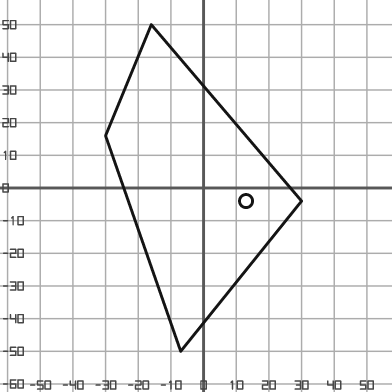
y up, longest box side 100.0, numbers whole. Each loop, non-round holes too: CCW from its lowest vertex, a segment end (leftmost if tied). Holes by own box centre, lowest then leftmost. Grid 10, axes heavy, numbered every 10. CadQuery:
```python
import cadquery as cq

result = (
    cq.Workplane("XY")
    .moveTo(-7.0, -50.0)
    .lineTo(30.0, -4.0)
    .lineTo(-16.0, 50.0)
    .lineTo(-30.0, 16.0)
    .close()
    .moveTo(13.0, -4.0)
    .circle(2.0)
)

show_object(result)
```